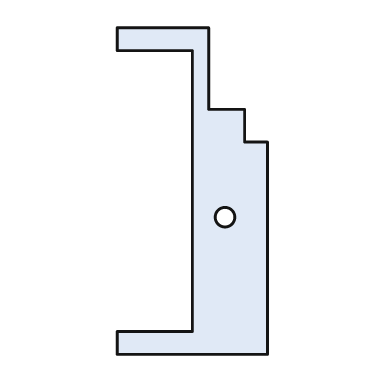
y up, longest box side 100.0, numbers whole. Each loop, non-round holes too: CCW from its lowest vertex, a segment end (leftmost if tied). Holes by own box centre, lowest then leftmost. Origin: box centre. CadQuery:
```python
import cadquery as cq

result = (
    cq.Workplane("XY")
    .moveTo(-23.0, -50.0)
    .lineTo(23.0, -50.0)
    .lineTo(23.0, 15.0)
    .lineTo(16.0, 15.0)
    .lineTo(16.0, 25.0)
    .lineTo(5.0, 25.0)
    .lineTo(5.0, 50.0)
    .lineTo(-23.0, 50.0)
    .lineTo(-23.0, 43.0)
    .lineTo(0.0, 43.0)
    .lineTo(0.0, -43.0)
    .lineTo(-23.0, -43.0)
    .close()
    .moveTo(10.0, -8.0)
    .circle(3.0)
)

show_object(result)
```